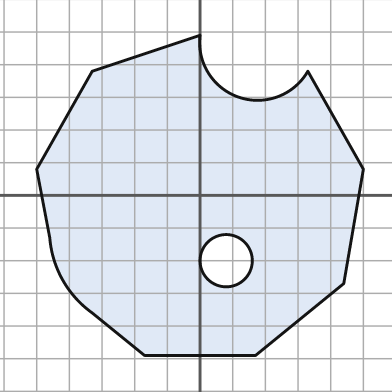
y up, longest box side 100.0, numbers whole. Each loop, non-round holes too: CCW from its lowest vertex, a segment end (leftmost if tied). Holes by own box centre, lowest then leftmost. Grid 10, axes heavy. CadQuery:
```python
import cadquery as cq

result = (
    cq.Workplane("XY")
    .moveTo(-17.0, -49.0)
    .lineTo(17.0, -49.0)
    .lineTo(44.0, -27.0)
    .lineTo(50.0, 8.0)
    .lineTo(33.0, 38.0)
    .threePointArc((12.0, 30.0), (0.0, 49.0))
    .lineTo(-33.0, 38.0)
    .lineTo(-50.0, 8.0)
    .lineTo(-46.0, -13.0)
    .threePointArc((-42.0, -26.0), (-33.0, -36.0))
    .close()
    .moveTo(8.0, -20.0)
    .circle(8.0)
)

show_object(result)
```